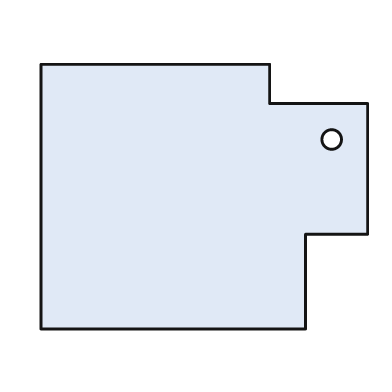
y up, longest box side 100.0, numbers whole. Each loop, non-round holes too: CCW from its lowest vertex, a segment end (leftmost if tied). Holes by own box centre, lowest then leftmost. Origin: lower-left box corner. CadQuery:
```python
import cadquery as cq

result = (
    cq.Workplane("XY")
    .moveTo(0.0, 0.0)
    .lineTo(81.0, 0.0)
    .lineTo(81.0, 29.0)
    .lineTo(100.0, 29.0)
    .lineTo(100.0, 69.0)
    .lineTo(70.0, 69.0)
    .lineTo(70.0, 81.0)
    .lineTo(0.0, 81.0)
    .close()
    .moveTo(89.0, 58.0)
    .circle(3.0)
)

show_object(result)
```